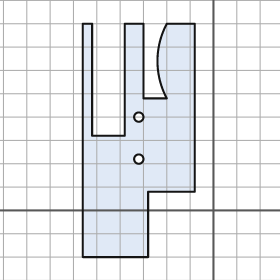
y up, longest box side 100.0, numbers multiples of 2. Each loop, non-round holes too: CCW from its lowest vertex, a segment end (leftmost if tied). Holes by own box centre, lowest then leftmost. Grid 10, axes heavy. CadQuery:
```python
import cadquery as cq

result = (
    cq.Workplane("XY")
    .moveTo(-56.0, -20.0)
    .lineTo(-28.0, -20.0)
    .lineTo(-28.0, 8.0)
    .lineTo(-8.0, 8.0)
    .lineTo(-8.0, 80.0)
    .lineTo(-20.0, 80.0)
    .threePointArc((-24.0, 64.0), (-20.0, 48.0))
    .lineTo(-30.0, 48.0)
    .lineTo(-30.0, 80.0)
    .lineTo(-38.0, 80.0)
    .lineTo(-38.0, 32.0)
    .lineTo(-52.0, 32.0)
    .lineTo(-52.0, 80.0)
    .lineTo(-56.0, 80.0)
    .close()
    .moveTo(-32.0, 22.0)
    .circle(2.0)
    .moveTo(-32.0, 40.0)
    .circle(2.0)
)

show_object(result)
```